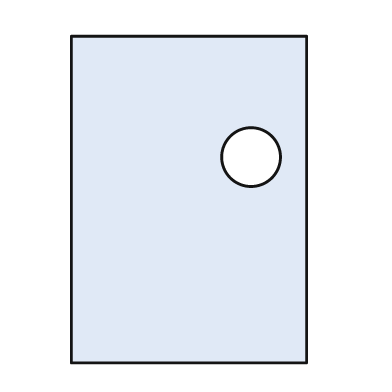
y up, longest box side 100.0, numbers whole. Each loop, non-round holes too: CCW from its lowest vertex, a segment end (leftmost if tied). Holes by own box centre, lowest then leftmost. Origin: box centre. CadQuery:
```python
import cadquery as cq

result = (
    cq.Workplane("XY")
    .moveTo(-36.0, -50.0)
    .lineTo(36.0, -50.0)
    .lineTo(36.0, 50.0)
    .lineTo(-36.0, 50.0)
    .close()
    .moveTo(19.0, 13.0)
    .circle(9.0)
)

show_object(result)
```